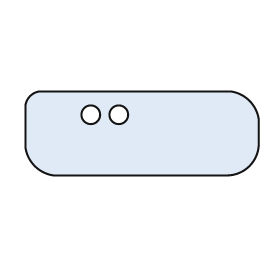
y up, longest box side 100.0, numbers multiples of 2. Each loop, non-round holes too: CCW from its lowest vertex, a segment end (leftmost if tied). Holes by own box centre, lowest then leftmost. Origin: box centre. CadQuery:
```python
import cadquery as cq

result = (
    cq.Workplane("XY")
    .moveTo(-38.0, -18.0)
    .lineTo(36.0, -18.0)
    .threePointArc((46.0, -14.0), (50.0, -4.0))
    .lineTo(50.0, 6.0)
    .threePointArc((46.0, 14.0), (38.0, 18.0))
    .lineTo(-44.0, 18.0)
    .threePointArc((-48.0, 16.0), (-50.0, 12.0))
    .lineTo(-50.0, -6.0)
    .threePointArc((-46.0, -14.0), (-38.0, -18.0))
    .close()
    .moveTo(-22.0, 8.0)
    .circle(4.0)
    .moveTo(-10.0, 8.0)
    .circle(4.0)
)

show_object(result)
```